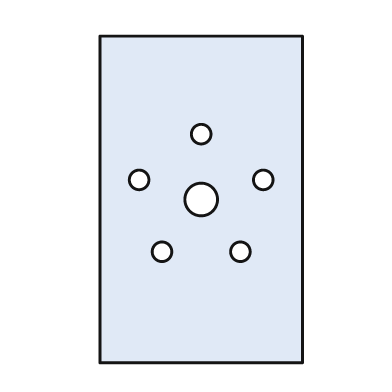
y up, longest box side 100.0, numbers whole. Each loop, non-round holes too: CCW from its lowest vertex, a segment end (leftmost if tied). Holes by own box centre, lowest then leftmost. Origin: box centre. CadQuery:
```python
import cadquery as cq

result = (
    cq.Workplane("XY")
    .moveTo(-31.0, -50.0)
    .lineTo(31.0, -50.0)
    .lineTo(31.0, 50.0)
    .lineTo(-31.0, 50.0)
    .close()
    .moveTo(-12.0, -16.0)
    .circle(3.0)
    .moveTo(12.0, -16.0)
    .circle(3.0)
    .moveTo(0.0, 0.0)
    .circle(5.0)
    .moveTo(-19.0, 6.0)
    .circle(3.0)
    .moveTo(19.0, 6.0)
    .circle(3.0)
    .moveTo(0.0, 20.0)
    .circle(3.0)
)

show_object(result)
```